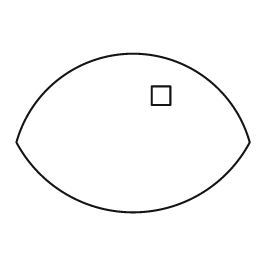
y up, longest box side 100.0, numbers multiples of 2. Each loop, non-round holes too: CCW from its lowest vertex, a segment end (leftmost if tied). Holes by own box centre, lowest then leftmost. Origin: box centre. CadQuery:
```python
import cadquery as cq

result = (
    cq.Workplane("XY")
    .moveTo(-50.0, -4.0)
    .threePointArc((0.0, -34.0), (50.0, -4.0))
    .threePointArc((0.0, 34.0), (-50.0, -4.0))
    .close()
    .moveTo(8.0, 12.0)
    .lineTo(16.0, 12.0)
    .lineTo(16.0, 20.0)
    .lineTo(8.0, 20.0)
    .close()
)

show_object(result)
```